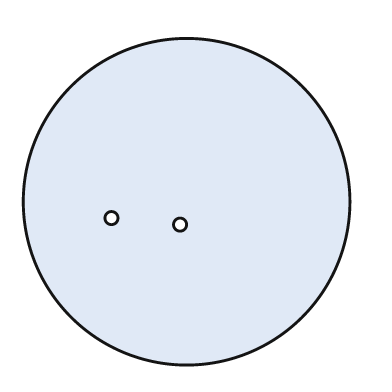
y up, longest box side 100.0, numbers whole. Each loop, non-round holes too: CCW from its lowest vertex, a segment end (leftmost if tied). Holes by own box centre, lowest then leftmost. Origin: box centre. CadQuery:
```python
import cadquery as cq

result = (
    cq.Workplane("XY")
    .moveTo(0.0, 0.0)
    .circle(50.0)
    .moveTo(-2.0, -7.0)
    .circle(2.0)
    .moveTo(-23.0, -5.0)
    .circle(2.0)
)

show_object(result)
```